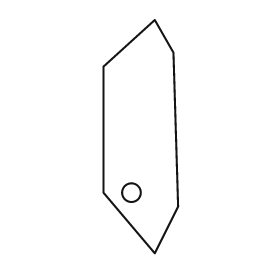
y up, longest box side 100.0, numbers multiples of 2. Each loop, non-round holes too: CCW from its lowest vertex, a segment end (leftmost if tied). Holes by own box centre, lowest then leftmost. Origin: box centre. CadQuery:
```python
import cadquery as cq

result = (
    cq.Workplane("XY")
    .moveTo(6.0, -50.0)
    .lineTo(16.0, -30.0)
    .lineTo(14.0, 36.0)
    .lineTo(6.0, 50.0)
    .lineTo(-16.0, 30.0)
    .lineTo(-16.0, -24.0)
    .close()
    .moveTo(-4.0, -24.0)
    .circle(4.0)
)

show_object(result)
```